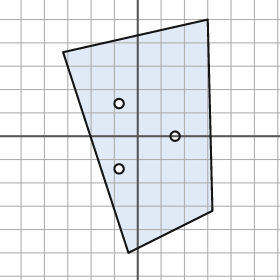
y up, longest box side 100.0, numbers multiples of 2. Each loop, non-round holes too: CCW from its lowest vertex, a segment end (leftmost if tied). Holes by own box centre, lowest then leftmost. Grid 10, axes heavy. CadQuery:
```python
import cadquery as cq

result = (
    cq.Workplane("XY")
    .moveTo(-4.0, -50.0)
    .lineTo(32.0, -32.0)
    .lineTo(30.0, 50.0)
    .lineTo(-32.0, 36.0)
    .close()
    .moveTo(-8.0, -14.0)
    .circle(2.0)
    .moveTo(16.0, 0.0)
    .circle(2.0)
    .moveTo(-8.0, 14.0)
    .circle(2.0)
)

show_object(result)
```